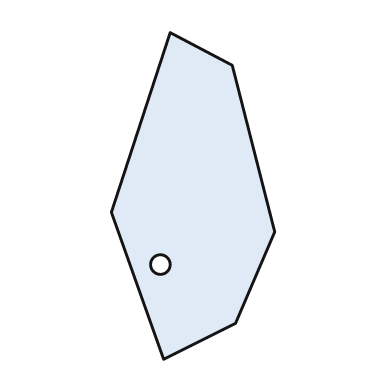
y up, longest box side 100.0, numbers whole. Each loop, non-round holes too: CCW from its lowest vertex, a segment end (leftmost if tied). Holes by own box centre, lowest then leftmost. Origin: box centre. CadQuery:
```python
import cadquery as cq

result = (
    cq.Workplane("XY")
    .moveTo(-9.0, -50.0)
    .lineTo(13.0, -39.0)
    .lineTo(25.0, -11.0)
    .lineTo(12.0, 40.0)
    .lineTo(-7.0, 50.0)
    .lineTo(-25.0, -5.0)
    .close()
    .moveTo(-10.0, -21.0)
    .circle(3.0)
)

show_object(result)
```